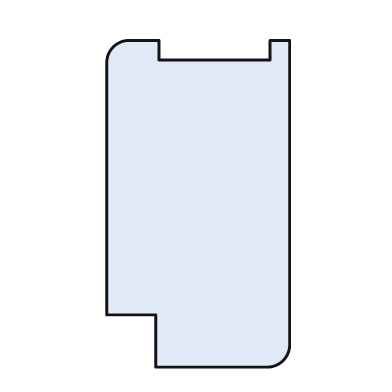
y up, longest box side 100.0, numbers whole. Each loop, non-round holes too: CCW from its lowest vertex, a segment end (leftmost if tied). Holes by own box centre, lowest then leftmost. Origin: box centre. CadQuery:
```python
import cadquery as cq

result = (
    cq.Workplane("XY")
    .moveTo(-13.0, -50.0)
    .lineTo(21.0, -50.0)
    .threePointArc((26.0, -48.0), (28.0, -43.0))
    .lineTo(28.0, 50.0)
    .lineTo(22.0, 50.0)
    .lineTo(22.0, 44.0)
    .lineTo(-12.0, 44.0)
    .lineTo(-12.0, 50.0)
    .lineTo(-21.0, 50.0)
    .threePointArc((-26.0, 48.0), (-28.0, 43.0))
    .lineTo(-28.0, -34.0)
    .lineTo(-13.0, -34.0)
    .close()
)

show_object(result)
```